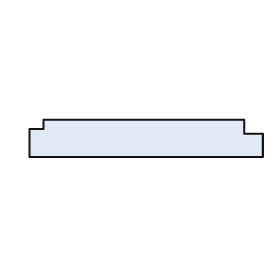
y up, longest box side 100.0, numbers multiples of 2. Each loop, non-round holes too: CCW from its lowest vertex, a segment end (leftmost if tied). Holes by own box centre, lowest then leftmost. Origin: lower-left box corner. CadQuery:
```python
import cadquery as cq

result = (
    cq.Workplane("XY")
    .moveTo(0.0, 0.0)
    .lineTo(100.0, 0.0)
    .lineTo(100.0, 10.0)
    .lineTo(92.0, 10.0)
    .lineTo(92.0, 16.0)
    .lineTo(6.0, 16.0)
    .lineTo(6.0, 12.0)
    .lineTo(0.0, 12.0)
    .close()
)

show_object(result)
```